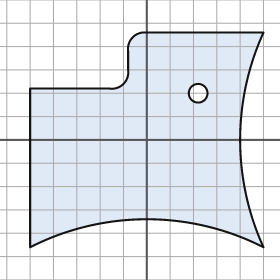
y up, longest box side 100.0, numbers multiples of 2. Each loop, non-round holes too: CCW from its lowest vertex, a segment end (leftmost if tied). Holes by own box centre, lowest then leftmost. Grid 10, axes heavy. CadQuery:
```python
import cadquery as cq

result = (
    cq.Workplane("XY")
    .moveTo(-50.0, -46.0)
    .threePointArc((0.0, -34.0), (50.0, -46.0))
    .threePointArc((40.0, 0.0), (50.0, 46.0))
    .lineTo(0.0, 46.0)
    .threePointArc((-6.0, 44.0), (-8.0, 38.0))
    .lineTo(-8.0, 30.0)
    .threePointArc((-10.0, 24.0), (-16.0, 22.0))
    .lineTo(-50.0, 22.0)
    .close()
    .moveTo(22.0, 20.0)
    .circle(4.0)
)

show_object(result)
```